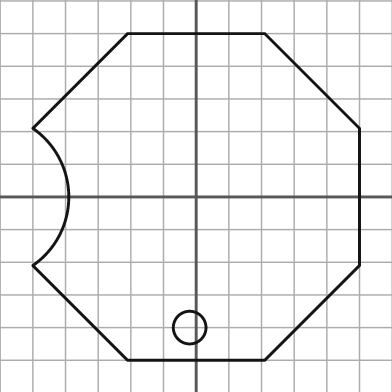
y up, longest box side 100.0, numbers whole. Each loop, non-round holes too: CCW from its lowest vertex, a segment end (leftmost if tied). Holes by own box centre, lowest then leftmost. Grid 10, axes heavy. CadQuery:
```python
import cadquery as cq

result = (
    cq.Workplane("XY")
    .moveTo(-21.0, -50.0)
    .lineTo(21.0, -50.0)
    .lineTo(50.0, -21.0)
    .lineTo(50.0, 21.0)
    .lineTo(21.0, 50.0)
    .lineTo(-21.0, 50.0)
    .lineTo(-50.0, 21.0)
    .threePointArc((-39.0, 0.0), (-50.0, -21.0))
    .close()
    .moveTo(-2.0, -40.0)
    .circle(5.0)
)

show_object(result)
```